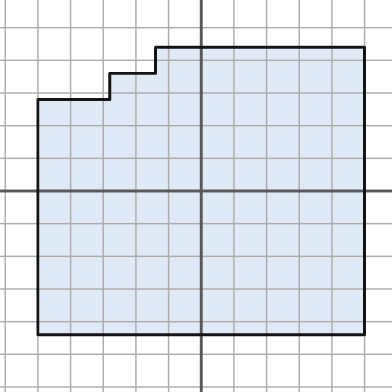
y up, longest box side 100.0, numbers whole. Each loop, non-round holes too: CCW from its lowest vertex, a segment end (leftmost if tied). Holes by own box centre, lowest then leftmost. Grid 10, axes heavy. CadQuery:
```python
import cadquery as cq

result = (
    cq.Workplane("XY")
    .moveTo(-50.0, -44.0)
    .lineTo(50.0, -44.0)
    .lineTo(50.0, 44.0)
    .lineTo(-14.0, 44.0)
    .lineTo(-14.0, 36.0)
    .lineTo(-28.0, 36.0)
    .lineTo(-28.0, 28.0)
    .lineTo(-50.0, 28.0)
    .close()
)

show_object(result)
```